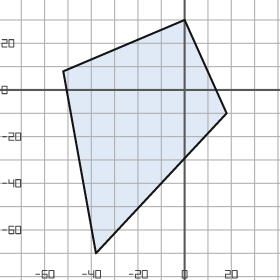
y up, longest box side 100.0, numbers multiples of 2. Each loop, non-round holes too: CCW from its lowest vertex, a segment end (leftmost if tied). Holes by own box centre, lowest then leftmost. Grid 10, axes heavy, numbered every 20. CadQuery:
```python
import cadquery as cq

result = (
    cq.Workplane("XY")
    .moveTo(-38.0, -70.0)
    .lineTo(18.0, -10.0)
    .lineTo(0.0, 30.0)
    .lineTo(-52.0, 8.0)
    .close()
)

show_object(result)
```